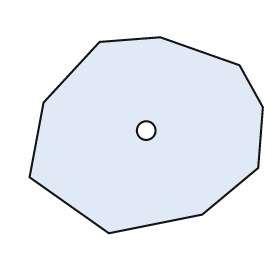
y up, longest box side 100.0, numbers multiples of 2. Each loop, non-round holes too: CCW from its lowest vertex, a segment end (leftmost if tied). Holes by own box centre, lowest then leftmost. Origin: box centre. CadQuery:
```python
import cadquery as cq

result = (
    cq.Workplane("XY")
    .moveTo(-16.0, -42.0)
    .lineTo(24.0, -34.0)
    .lineTo(48.0, -14.0)
    .lineTo(50.0, 12.0)
    .lineTo(40.0, 30.0)
    .lineTo(6.0, 42.0)
    .lineTo(-20.0, 40.0)
    .lineTo(-44.0, 14.0)
    .lineTo(-50.0, -18.0)
    .close()
    .moveTo(0.0, 2.0)
    .circle(4.0)
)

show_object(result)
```